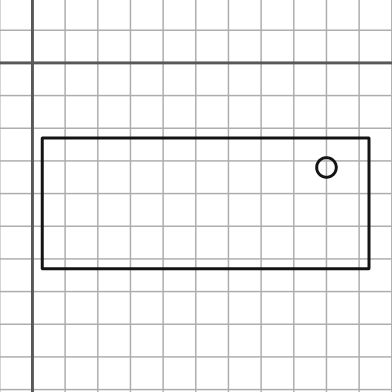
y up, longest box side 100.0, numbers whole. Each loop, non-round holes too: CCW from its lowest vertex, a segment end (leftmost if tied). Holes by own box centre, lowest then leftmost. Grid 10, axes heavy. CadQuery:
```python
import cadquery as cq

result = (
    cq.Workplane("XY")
    .moveTo(3.0, -63.0)
    .lineTo(103.0, -63.0)
    .lineTo(103.0, -23.0)
    .lineTo(3.0, -23.0)
    .close()
    .moveTo(90.0, -32.0)
    .circle(3.0)
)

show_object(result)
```